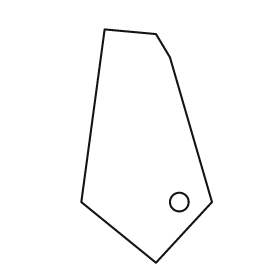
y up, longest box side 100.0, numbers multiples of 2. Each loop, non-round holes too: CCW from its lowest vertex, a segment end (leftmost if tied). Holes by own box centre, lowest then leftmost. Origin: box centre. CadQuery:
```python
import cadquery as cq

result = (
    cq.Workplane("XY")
    .moveTo(4.0, -50.0)
    .lineTo(28.0, -24.0)
    .lineTo(10.0, 38.0)
    .lineTo(4.0, 48.0)
    .lineTo(-18.0, 50.0)
    .lineTo(-28.0, -24.0)
    .close()
    .moveTo(14.0, -24.0)
    .circle(4.0)
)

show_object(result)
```